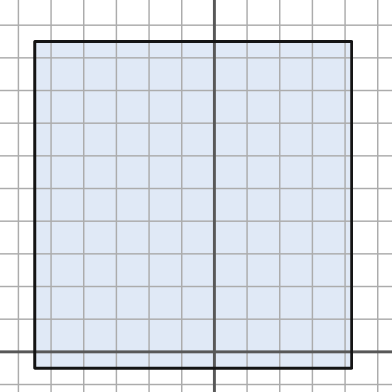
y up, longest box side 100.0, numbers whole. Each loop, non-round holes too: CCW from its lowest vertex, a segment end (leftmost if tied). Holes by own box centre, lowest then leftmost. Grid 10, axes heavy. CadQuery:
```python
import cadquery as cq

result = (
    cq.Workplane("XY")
    .moveTo(-55.0, -5.0)
    .lineTo(42.0, -5.0)
    .lineTo(42.0, 95.0)
    .lineTo(-55.0, 95.0)
    .close()
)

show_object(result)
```